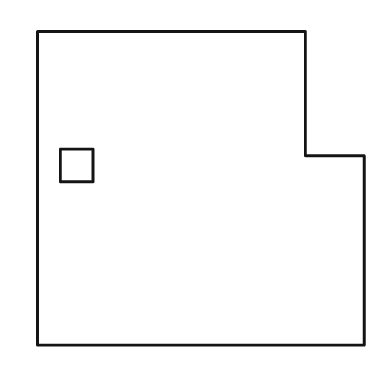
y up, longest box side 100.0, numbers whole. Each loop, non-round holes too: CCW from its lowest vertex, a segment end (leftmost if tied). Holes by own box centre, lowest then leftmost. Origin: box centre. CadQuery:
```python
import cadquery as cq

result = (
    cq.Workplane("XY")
    .moveTo(-50.0, -48.0)
    .lineTo(50.0, -48.0)
    .lineTo(50.0, 10.0)
    .lineTo(32.0, 10.0)
    .lineTo(32.0, 48.0)
    .lineTo(-50.0, 48.0)
    .close()
    .moveTo(-43.0, 2.0)
    .lineTo(-33.0, 2.0)
    .lineTo(-33.0, 12.0)
    .lineTo(-43.0, 12.0)
    .close()
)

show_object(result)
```